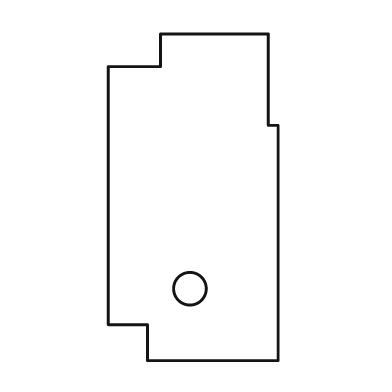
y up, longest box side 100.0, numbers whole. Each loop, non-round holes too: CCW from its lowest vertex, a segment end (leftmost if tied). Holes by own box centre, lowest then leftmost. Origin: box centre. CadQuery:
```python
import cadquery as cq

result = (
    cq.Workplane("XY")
    .moveTo(-14.0, -50.0)
    .lineTo(26.0, -50.0)
    .lineTo(26.0, 22.0)
    .lineTo(23.0, 22.0)
    .lineTo(23.0, 50.0)
    .lineTo(-10.0, 50.0)
    .lineTo(-10.0, 40.0)
    .lineTo(-26.0, 40.0)
    .lineTo(-26.0, -39.0)
    .lineTo(-14.0, -39.0)
    .close()
    .moveTo(-1.0, -28.0)
    .circle(5.0)
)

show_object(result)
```